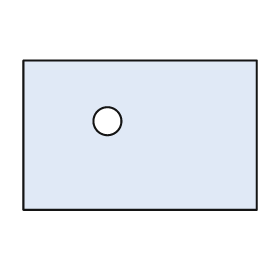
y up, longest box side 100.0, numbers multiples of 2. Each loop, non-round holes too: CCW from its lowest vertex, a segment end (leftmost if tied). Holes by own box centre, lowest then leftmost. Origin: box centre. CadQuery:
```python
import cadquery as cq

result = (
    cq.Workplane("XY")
    .moveTo(-50.0, -32.0)
    .lineTo(50.0, -32.0)
    .lineTo(50.0, 32.0)
    .lineTo(-50.0, 32.0)
    .close()
    .moveTo(-14.0, 6.0)
    .circle(6.0)
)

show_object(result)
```